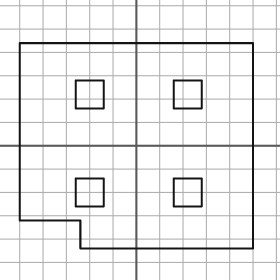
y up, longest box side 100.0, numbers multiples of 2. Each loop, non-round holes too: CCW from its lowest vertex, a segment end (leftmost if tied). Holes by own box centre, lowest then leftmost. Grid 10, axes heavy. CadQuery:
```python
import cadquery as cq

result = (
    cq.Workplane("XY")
    .moveTo(-24.0, -44.0)
    .lineTo(50.0, -44.0)
    .lineTo(50.0, 44.0)
    .lineTo(-50.0, 44.0)
    .lineTo(-50.0, -32.0)
    .lineTo(-24.0, -32.0)
    .close()
    .moveTo(-26.0, -26.0)
    .lineTo(-14.0, -26.0)
    .lineTo(-14.0, -14.0)
    .lineTo(-26.0, -14.0)
    .close()
    .moveTo(16.0, -26.0)
    .lineTo(28.0, -26.0)
    .lineTo(28.0, -14.0)
    .lineTo(16.0, -14.0)
    .close()
    .moveTo(-26.0, 16.0)
    .lineTo(-14.0, 16.0)
    .lineTo(-14.0, 28.0)
    .lineTo(-26.0, 28.0)
    .close()
    .moveTo(16.0, 16.0)
    .lineTo(28.0, 16.0)
    .lineTo(28.0, 28.0)
    .lineTo(16.0, 28.0)
    .close()
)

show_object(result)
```